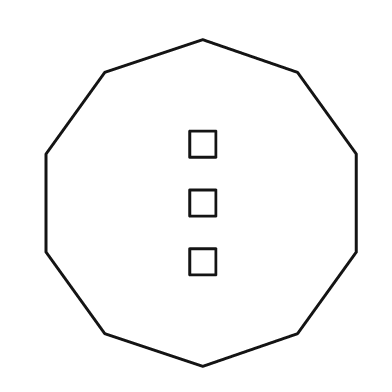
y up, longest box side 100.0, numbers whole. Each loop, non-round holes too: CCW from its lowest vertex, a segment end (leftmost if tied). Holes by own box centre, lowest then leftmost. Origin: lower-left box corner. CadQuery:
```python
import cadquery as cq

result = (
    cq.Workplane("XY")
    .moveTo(48.0, 0.0)
    .lineTo(77.0, 10.0)
    .lineTo(95.0, 35.0)
    .lineTo(95.0, 65.0)
    .lineTo(77.0, 90.0)
    .lineTo(48.0, 100.0)
    .lineTo(18.0, 90.0)
    .lineTo(0.0, 65.0)
    .lineTo(0.0, 35.0)
    .lineTo(18.0, 10.0)
    .close()
    .moveTo(44.0, 28.0)
    .lineTo(52.0, 28.0)
    .lineTo(52.0, 36.0)
    .lineTo(44.0, 36.0)
    .close()
    .moveTo(44.0, 46.0)
    .lineTo(52.0, 46.0)
    .lineTo(52.0, 54.0)
    .lineTo(44.0, 54.0)
    .close()
    .moveTo(44.0, 64.0)
    .lineTo(52.0, 64.0)
    .lineTo(52.0, 72.0)
    .lineTo(44.0, 72.0)
    .close()
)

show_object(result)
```